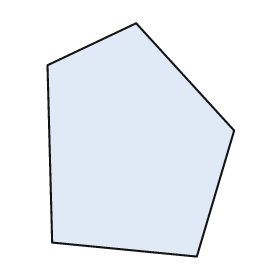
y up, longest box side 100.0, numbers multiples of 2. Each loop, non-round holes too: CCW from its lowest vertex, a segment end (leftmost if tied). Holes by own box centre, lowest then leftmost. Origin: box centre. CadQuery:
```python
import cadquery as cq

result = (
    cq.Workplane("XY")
    .moveTo(24.0, -50.0)
    .lineTo(40.0, 4.0)
    .lineTo(-2.0, 50.0)
    .lineTo(-40.0, 32.0)
    .lineTo(-38.0, -44.0)
    .close()
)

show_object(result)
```